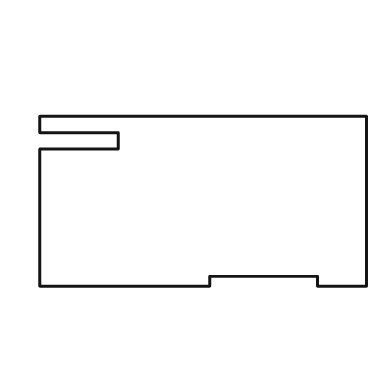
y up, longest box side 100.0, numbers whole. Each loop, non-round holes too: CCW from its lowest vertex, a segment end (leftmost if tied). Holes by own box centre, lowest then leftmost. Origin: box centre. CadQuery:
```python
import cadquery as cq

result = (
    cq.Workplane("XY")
    .moveTo(-50.0, -26.0)
    .lineTo(2.0, -26.0)
    .lineTo(2.0, -23.0)
    .lineTo(35.0, -23.0)
    .lineTo(35.0, -26.0)
    .lineTo(50.0, -26.0)
    .lineTo(50.0, 26.0)
    .lineTo(-50.0, 26.0)
    .lineTo(-50.0, 21.0)
    .lineTo(-26.0, 21.0)
    .lineTo(-26.0, 16.0)
    .lineTo(-50.0, 16.0)
    .close()
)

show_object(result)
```